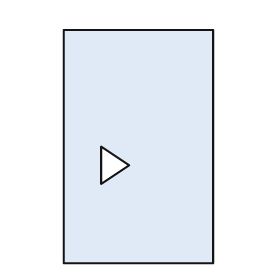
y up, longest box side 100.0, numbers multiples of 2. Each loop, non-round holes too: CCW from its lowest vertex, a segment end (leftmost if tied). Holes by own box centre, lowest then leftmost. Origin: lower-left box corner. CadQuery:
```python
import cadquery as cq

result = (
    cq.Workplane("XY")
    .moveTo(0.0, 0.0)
    .lineTo(64.0, 0.0)
    .lineTo(64.0, 100.0)
    .lineTo(0.0, 100.0)
    .close()
    .moveTo(16.0, 34.0)
    .lineTo(28.0, 42.0)
    .lineTo(16.0, 50.0)
    .close()
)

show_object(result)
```